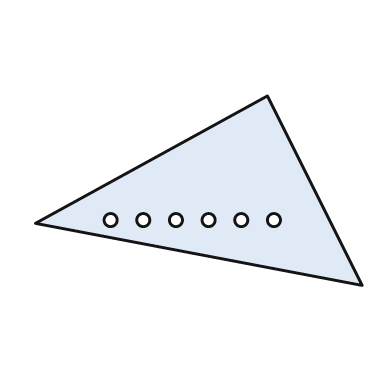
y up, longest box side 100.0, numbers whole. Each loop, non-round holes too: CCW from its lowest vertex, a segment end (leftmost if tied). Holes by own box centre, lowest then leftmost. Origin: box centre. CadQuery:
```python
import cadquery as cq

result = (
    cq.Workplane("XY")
    .moveTo(50.0, -29.0)
    .lineTo(21.0, 29.0)
    .lineTo(-50.0, -10.0)
    .close()
    .moveTo(-27.0, -9.0)
    .circle(2.0)
    .moveTo(-17.0, -9.0)
    .circle(2.0)
    .moveTo(-7.0, -9.0)
    .circle(2.0)
    .moveTo(3.0, -9.0)
    .circle(2.0)
    .moveTo(13.0, -9.0)
    .circle(2.0)
    .moveTo(23.0, -9.0)
    .circle(2.0)
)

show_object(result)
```